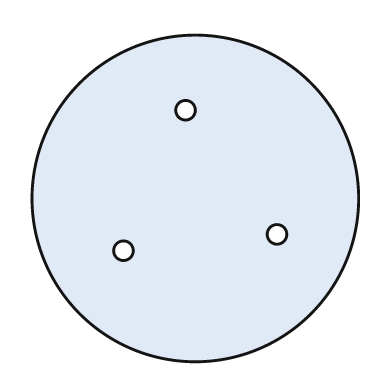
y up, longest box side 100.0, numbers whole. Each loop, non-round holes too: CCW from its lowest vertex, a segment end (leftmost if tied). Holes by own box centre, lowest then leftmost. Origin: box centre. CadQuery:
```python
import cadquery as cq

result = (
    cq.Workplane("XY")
    .moveTo(0.0, 0.0)
    .circle(50.0)
    .moveTo(-22.0, -16.0)
    .circle(3.0)
    .moveTo(25.0, -11.0)
    .circle(3.0)
    .moveTo(-3.0, 27.0)
    .circle(3.0)
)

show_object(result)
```